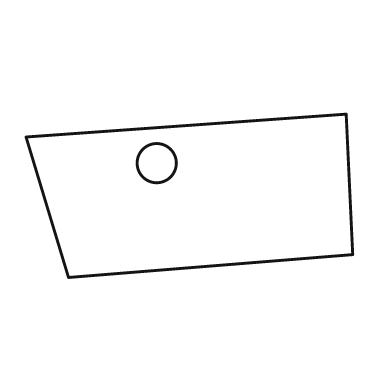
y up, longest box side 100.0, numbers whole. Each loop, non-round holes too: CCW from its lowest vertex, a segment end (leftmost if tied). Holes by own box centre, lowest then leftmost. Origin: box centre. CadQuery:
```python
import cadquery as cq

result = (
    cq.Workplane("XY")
    .moveTo(-37.0, -25.0)
    .lineTo(50.0, -18.0)
    .lineTo(48.0, 25.0)
    .lineTo(-50.0, 18.0)
    .close()
    .moveTo(-10.0, 10.0)
    .circle(6.0)
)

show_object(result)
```